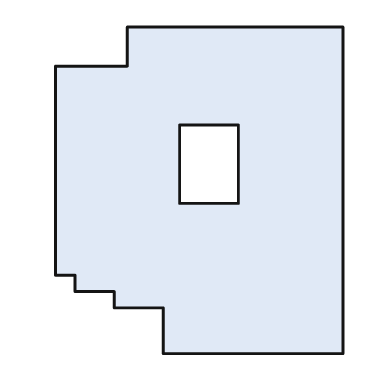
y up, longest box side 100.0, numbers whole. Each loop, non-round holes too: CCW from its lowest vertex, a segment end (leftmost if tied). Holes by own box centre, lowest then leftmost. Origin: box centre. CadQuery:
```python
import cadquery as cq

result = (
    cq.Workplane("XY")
    .moveTo(-11.0, -50.0)
    .lineTo(44.0, -50.0)
    .lineTo(44.0, 50.0)
    .lineTo(-22.0, 50.0)
    .lineTo(-22.0, 38.0)
    .lineTo(-44.0, 38.0)
    .lineTo(-44.0, -26.0)
    .lineTo(-38.0, -26.0)
    .lineTo(-38.0, -31.0)
    .lineTo(-26.0, -31.0)
    .lineTo(-26.0, -36.0)
    .lineTo(-11.0, -36.0)
    .close()
    .moveTo(-6.0, -4.0)
    .lineTo(12.0, -4.0)
    .lineTo(12.0, 20.0)
    .lineTo(-6.0, 20.0)
    .close()
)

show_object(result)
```